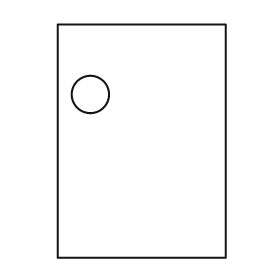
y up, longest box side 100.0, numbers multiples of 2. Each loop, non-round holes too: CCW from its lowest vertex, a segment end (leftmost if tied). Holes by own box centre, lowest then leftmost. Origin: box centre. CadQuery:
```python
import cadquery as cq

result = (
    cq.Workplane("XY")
    .moveTo(-36.0, -50.0)
    .lineTo(36.0, -50.0)
    .lineTo(36.0, 50.0)
    .lineTo(-36.0, 50.0)
    .close()
    .moveTo(-22.0, 20.0)
    .circle(8.0)
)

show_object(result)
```